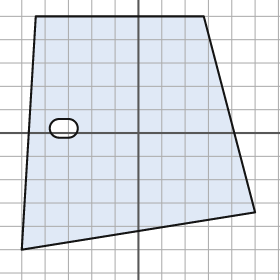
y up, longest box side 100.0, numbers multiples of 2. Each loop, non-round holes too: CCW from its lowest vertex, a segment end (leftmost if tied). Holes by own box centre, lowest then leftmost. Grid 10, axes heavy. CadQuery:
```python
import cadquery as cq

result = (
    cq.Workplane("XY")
    .moveTo(-50.0, -50.0)
    .lineTo(50.0, -34.0)
    .lineTo(28.0, 50.0)
    .lineTo(-44.0, 50.0)
    .close()
    .moveTo(-34.0, -2.0)
    .lineTo(-30.0, -2.0)
    .threePointArc((-26.0, 2.0), (-30.0, 6.0))
    .lineTo(-34.0, 6.0)
    .threePointArc((-38.0, 2.0), (-34.0, -2.0))
    .close()
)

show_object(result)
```